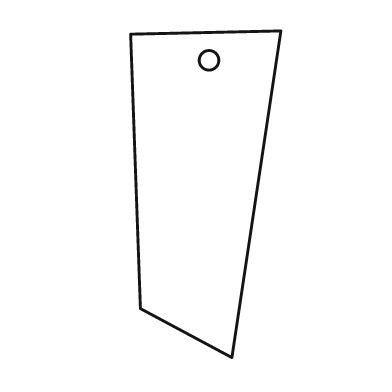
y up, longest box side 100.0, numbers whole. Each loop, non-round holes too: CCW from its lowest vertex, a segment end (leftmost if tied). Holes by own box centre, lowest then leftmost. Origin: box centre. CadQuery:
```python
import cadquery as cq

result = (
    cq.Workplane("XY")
    .moveTo(8.0, -50.0)
    .lineTo(23.0, 50.0)
    .lineTo(-23.0, 49.0)
    .lineTo(-20.0, -35.0)
    .close()
    .moveTo(1.0, 41.0)
    .circle(3.0)
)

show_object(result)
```